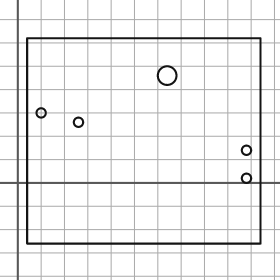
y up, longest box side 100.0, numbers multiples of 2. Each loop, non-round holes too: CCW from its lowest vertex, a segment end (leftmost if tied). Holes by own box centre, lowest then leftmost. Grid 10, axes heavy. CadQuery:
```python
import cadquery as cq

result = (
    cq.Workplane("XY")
    .moveTo(4.0, -26.0)
    .lineTo(104.0, -26.0)
    .lineTo(104.0, 62.0)
    .lineTo(4.0, 62.0)
    .close()
    .moveTo(98.0, 2.0)
    .circle(2.0)
    .moveTo(98.0, 14.0)
    .circle(2.0)
    .moveTo(26.0, 26.0)
    .circle(2.0)
    .moveTo(10.0, 30.0)
    .circle(2.0)
    .moveTo(64.0, 46.0)
    .circle(4.0)
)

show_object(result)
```